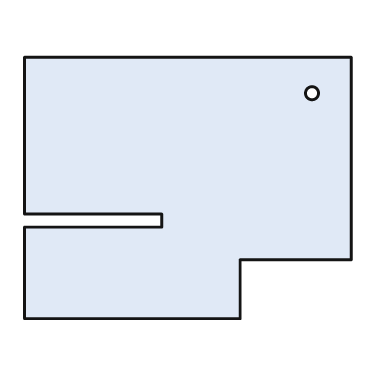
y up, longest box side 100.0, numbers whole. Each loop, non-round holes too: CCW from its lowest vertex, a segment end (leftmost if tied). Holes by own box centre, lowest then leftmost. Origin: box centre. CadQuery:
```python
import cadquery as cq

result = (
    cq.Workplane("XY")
    .moveTo(-50.0, -40.0)
    .lineTo(16.0, -40.0)
    .lineTo(16.0, -22.0)
    .lineTo(50.0, -22.0)
    .lineTo(50.0, 40.0)
    .lineTo(-50.0, 40.0)
    .lineTo(-50.0, -8.0)
    .lineTo(-8.0, -8.0)
    .lineTo(-8.0, -12.0)
    .lineTo(-50.0, -12.0)
    .close()
    .moveTo(38.0, 29.0)
    .circle(2.0)
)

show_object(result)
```